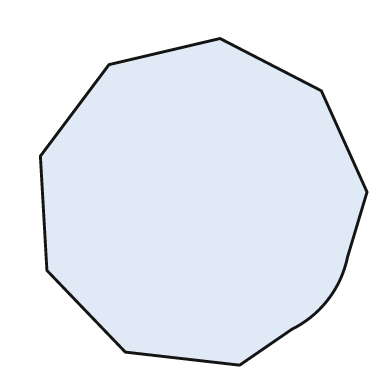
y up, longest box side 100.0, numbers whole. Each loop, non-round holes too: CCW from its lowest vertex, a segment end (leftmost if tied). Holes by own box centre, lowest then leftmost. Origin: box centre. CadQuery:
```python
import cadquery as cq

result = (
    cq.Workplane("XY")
    .moveTo(11.0, -50.0)
    .lineTo(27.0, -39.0)
    .threePointArc((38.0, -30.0), (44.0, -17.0))
    .lineTo(50.0, 3.0)
    .lineTo(36.0, 34.0)
    .lineTo(5.0, 50.0)
    .lineTo(-29.0, 42.0)
    .lineTo(-50.0, 14.0)
    .lineTo(-48.0, -21.0)
    .lineTo(-24.0, -46.0)
    .close()
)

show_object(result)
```